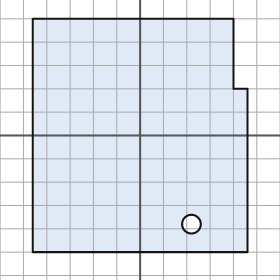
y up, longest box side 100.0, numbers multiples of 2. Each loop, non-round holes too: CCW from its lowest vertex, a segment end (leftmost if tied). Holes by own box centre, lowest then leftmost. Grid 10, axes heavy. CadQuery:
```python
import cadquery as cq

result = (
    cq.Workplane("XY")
    .moveTo(-46.0, -50.0)
    .lineTo(46.0, -50.0)
    .lineTo(46.0, 20.0)
    .lineTo(40.0, 20.0)
    .lineTo(40.0, 50.0)
    .lineTo(-46.0, 50.0)
    .close()
    .moveTo(22.0, -38.0)
    .circle(4.0)
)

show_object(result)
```